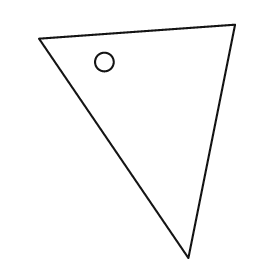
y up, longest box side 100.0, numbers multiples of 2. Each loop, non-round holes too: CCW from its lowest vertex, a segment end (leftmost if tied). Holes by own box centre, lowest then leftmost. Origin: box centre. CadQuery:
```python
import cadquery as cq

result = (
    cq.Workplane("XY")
    .moveTo(22.0, -50.0)
    .lineTo(42.0, 50.0)
    .lineTo(-42.0, 44.0)
    .close()
    .moveTo(-14.0, 34.0)
    .circle(4.0)
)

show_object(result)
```